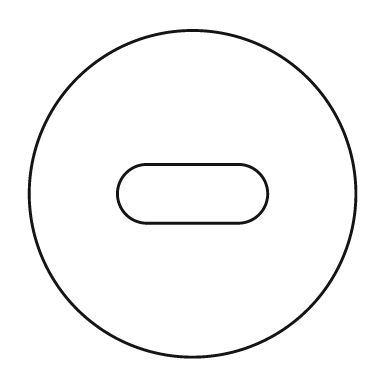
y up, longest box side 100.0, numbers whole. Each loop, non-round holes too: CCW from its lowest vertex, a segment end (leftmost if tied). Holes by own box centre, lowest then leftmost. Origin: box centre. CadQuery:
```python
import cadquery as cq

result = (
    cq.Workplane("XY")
    .moveTo(0.0, 0.0)
    .circle(50.0)
    .moveTo(-14.0, -9.0)
    .lineTo(14.0, -9.0)
    .threePointArc((23.0, 0.0), (14.0, 9.0))
    .lineTo(-14.0, 9.0)
    .threePointArc((-23.0, 0.0), (-14.0, -9.0))
    .close()
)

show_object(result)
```